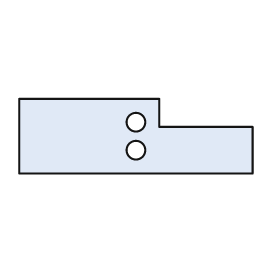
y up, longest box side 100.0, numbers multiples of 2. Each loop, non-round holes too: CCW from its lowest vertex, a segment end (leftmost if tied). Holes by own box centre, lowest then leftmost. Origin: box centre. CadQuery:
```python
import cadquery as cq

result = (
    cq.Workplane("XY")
    .moveTo(-50.0, -16.0)
    .lineTo(50.0, -16.0)
    .lineTo(50.0, 4.0)
    .lineTo(10.0, 4.0)
    .lineTo(10.0, 16.0)
    .lineTo(-50.0, 16.0)
    .close()
    .moveTo(0.0, -6.0)
    .circle(4.0)
    .moveTo(0.0, 6.0)
    .circle(4.0)
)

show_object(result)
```